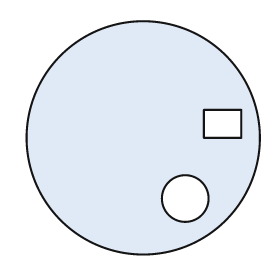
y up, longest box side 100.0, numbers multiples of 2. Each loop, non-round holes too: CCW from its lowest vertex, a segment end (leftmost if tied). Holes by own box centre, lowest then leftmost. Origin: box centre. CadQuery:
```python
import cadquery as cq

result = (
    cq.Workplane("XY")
    .moveTo(0.0, 0.0)
    .circle(50.0)
    .moveTo(18.0, -26.0)
    .circle(10.0)
    .moveTo(26.0, 0.0)
    .lineTo(42.0, 0.0)
    .lineTo(42.0, 12.0)
    .lineTo(26.0, 12.0)
    .close()
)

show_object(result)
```